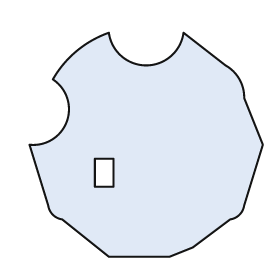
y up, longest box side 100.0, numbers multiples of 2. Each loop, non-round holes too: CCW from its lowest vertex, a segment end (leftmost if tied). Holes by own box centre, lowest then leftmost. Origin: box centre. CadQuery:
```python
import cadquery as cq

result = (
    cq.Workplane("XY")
    .moveTo(-16.0, -48.0)
    .lineTo(10.0, -48.0)
    .lineTo(20.0, -44.0)
    .lineTo(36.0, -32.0)
    .threePointArc((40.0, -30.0), (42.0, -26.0))
    .lineTo(50.0, 0.0)
    .lineTo(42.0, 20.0)
    .threePointArc((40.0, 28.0), (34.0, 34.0))
    .lineTo(16.0, 48.0)
    .threePointArc((0.0, 34.0), (-16.0, 48.0))
    .threePointArc((-30.0, 40.0), (-40.0, 28.0))
    .threePointArc((-34.0, 10.0), (-50.0, 0.0))
    .lineTo(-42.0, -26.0)
    .threePointArc((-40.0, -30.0), (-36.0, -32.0))
    .close()
    .moveTo(-22.0, -18.0)
    .lineTo(-14.0, -18.0)
    .lineTo(-14.0, -6.0)
    .lineTo(-22.0, -6.0)
    .close()
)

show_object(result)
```